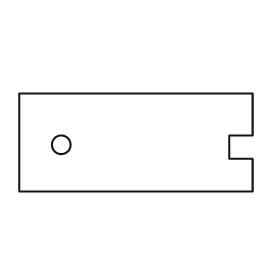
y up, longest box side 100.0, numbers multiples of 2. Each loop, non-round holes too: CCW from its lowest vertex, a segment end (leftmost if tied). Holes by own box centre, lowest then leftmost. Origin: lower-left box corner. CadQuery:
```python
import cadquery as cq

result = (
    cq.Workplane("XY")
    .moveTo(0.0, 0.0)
    .lineTo(100.0, 0.0)
    .lineTo(100.0, 14.0)
    .lineTo(90.0, 14.0)
    .lineTo(90.0, 24.0)
    .lineTo(100.0, 24.0)
    .lineTo(100.0, 42.0)
    .lineTo(0.0, 42.0)
    .close()
    .moveTo(18.0, 20.0)
    .circle(4.0)
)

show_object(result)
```